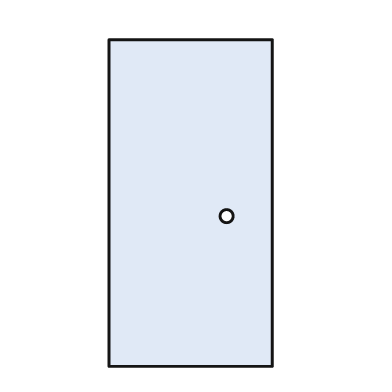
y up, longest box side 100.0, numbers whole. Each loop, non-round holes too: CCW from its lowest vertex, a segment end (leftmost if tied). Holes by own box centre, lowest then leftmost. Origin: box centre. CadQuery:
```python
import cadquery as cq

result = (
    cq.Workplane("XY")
    .moveTo(-25.0, -50.0)
    .lineTo(25.0, -50.0)
    .lineTo(25.0, 50.0)
    .lineTo(-25.0, 50.0)
    .close()
    .moveTo(11.0, -4.0)
    .circle(2.0)
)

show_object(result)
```